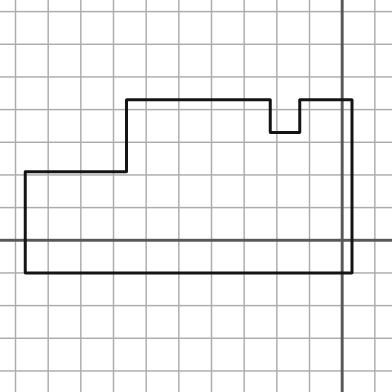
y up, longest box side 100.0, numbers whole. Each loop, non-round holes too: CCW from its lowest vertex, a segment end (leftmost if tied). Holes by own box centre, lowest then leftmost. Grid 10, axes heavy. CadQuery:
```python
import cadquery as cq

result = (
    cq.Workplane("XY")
    .moveTo(-97.0, -10.0)
    .lineTo(3.0, -10.0)
    .lineTo(3.0, 43.0)
    .lineTo(-13.0, 43.0)
    .lineTo(-13.0, 33.0)
    .lineTo(-22.0, 33.0)
    .lineTo(-22.0, 43.0)
    .lineTo(-66.0, 43.0)
    .lineTo(-66.0, 21.0)
    .lineTo(-97.0, 21.0)
    .close()
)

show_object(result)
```